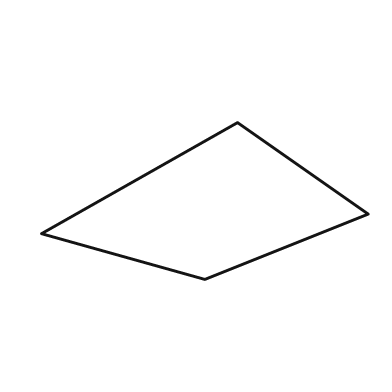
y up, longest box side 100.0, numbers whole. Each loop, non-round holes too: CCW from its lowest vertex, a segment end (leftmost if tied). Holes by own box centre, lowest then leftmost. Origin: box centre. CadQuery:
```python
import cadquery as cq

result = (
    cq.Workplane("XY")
    .moveTo(0.0, -24.0)
    .lineTo(50.0, -4.0)
    .lineTo(10.0, 24.0)
    .lineTo(-50.0, -10.0)
    .close()
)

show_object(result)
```